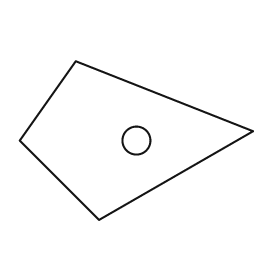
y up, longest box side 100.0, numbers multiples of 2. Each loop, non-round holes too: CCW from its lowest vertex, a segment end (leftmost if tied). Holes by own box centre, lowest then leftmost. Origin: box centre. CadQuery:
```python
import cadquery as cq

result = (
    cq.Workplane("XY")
    .moveTo(-16.0, -34.0)
    .lineTo(50.0, 4.0)
    .lineTo(-26.0, 34.0)
    .lineTo(-50.0, 0.0)
    .close()
    .moveTo(0.0, 0.0)
    .circle(6.0)
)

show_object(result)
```